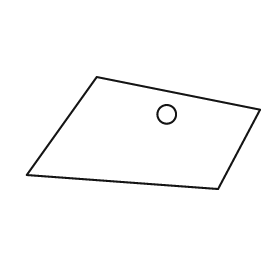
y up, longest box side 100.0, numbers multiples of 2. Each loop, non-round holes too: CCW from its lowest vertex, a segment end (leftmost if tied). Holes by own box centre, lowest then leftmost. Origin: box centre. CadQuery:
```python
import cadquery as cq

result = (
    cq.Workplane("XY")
    .moveTo(32.0, -24.0)
    .lineTo(50.0, 10.0)
    .lineTo(-20.0, 24.0)
    .lineTo(-50.0, -18.0)
    .close()
    .moveTo(10.0, 8.0)
    .circle(4.0)
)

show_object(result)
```